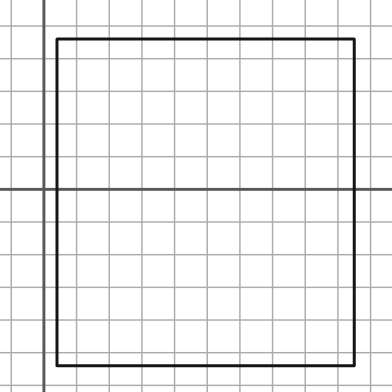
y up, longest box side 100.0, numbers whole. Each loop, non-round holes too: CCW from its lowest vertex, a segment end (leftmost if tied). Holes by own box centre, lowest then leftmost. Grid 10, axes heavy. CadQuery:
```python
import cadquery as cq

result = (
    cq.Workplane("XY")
    .moveTo(4.0, -54.0)
    .lineTo(95.0, -54.0)
    .lineTo(95.0, 46.0)
    .lineTo(4.0, 46.0)
    .close()
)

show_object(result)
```